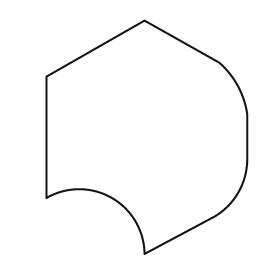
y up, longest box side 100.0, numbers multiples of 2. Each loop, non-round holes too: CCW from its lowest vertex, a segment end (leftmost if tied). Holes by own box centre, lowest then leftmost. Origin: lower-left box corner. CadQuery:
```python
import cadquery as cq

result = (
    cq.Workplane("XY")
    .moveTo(42.0, 0.0)
    .lineTo(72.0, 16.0)
    .threePointArc((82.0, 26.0), (86.0, 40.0))
    .lineTo(86.0, 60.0)
    .threePointArc((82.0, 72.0), (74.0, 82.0))
    .lineTo(42.0, 100.0)
    .lineTo(0.0, 76.0)
    .lineTo(0.0, 24.0)
    .threePointArc((28.0, 24.0), (42.0, 0.0))
    .close()
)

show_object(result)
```